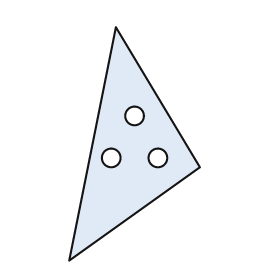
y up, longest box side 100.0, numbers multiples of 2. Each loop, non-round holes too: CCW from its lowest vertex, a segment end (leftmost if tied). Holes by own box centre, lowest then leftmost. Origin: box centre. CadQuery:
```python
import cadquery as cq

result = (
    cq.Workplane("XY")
    .moveTo(-28.0, -50.0)
    .lineTo(28.0, -10.0)
    .lineTo(-8.0, 50.0)
    .close()
    .moveTo(-10.0, -6.0)
    .circle(4.0)
    .moveTo(10.0, -6.0)
    .circle(4.0)
    .moveTo(0.0, 12.0)
    .circle(4.0)
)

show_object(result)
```